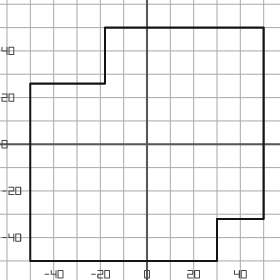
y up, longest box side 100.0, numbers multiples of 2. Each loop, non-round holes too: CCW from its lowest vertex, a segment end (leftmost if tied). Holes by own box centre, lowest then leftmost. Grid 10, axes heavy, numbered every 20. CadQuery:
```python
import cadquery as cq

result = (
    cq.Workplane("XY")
    .moveTo(-50.0, -50.0)
    .lineTo(30.0, -50.0)
    .lineTo(30.0, -32.0)
    .lineTo(50.0, -32.0)
    .lineTo(50.0, 50.0)
    .lineTo(-18.0, 50.0)
    .lineTo(-18.0, 26.0)
    .lineTo(-50.0, 26.0)
    .close()
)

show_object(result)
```